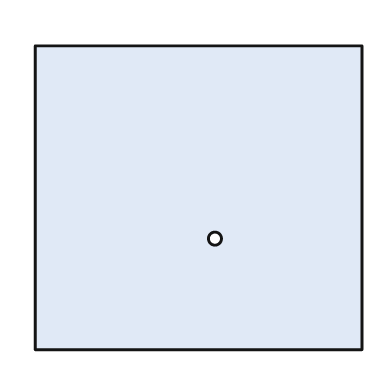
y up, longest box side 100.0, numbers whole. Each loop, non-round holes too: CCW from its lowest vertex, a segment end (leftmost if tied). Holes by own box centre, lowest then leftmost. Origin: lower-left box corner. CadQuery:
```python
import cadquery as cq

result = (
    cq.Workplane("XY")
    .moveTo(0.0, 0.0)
    .lineTo(100.0, 0.0)
    .lineTo(100.0, 93.0)
    .lineTo(0.0, 93.0)
    .close()
    .moveTo(55.0, 34.0)
    .circle(2.0)
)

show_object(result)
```